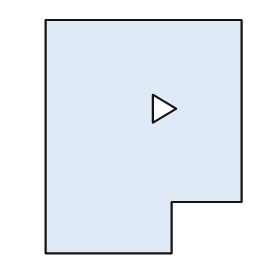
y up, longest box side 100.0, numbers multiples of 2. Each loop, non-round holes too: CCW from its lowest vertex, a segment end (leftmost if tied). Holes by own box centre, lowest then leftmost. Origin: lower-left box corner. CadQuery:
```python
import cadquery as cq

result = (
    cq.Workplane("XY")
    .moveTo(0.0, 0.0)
    .lineTo(54.0, 0.0)
    .lineTo(54.0, 22.0)
    .lineTo(84.0, 22.0)
    .lineTo(84.0, 100.0)
    .lineTo(0.0, 100.0)
    .close()
    .moveTo(46.0, 56.0)
    .lineTo(56.0, 62.0)
    .lineTo(46.0, 68.0)
    .close()
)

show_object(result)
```